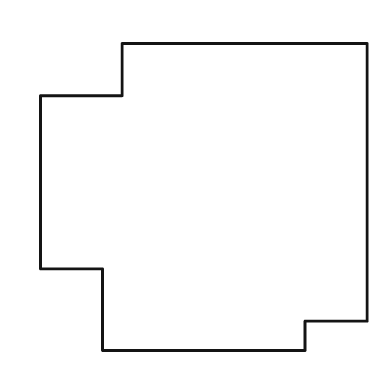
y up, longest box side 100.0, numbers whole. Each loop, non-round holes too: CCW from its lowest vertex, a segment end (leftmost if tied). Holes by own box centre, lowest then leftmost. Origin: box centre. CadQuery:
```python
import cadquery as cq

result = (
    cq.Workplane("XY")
    .moveTo(-31.0, -47.0)
    .lineTo(31.0, -47.0)
    .lineTo(31.0, -38.0)
    .lineTo(50.0, -38.0)
    .lineTo(50.0, 47.0)
    .lineTo(-25.0, 47.0)
    .lineTo(-25.0, 31.0)
    .lineTo(-50.0, 31.0)
    .lineTo(-50.0, -22.0)
    .lineTo(-31.0, -22.0)
    .close()
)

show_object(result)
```